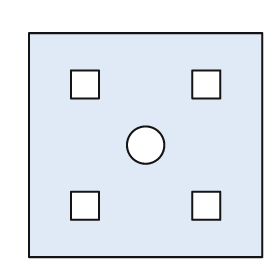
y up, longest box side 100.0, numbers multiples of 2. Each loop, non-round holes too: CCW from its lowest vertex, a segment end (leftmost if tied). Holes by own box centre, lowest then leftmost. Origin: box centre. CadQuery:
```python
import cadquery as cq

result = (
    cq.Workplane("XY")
    .moveTo(-50.0, -48.0)
    .lineTo(50.0, -48.0)
    .lineTo(50.0, 48.0)
    .lineTo(-50.0, 48.0)
    .close()
    .moveTo(-32.0, -32.0)
    .lineTo(-20.0, -32.0)
    .lineTo(-20.0, -20.0)
    .lineTo(-32.0, -20.0)
    .close()
    .moveTo(20.0, -32.0)
    .lineTo(32.0, -32.0)
    .lineTo(32.0, -20.0)
    .lineTo(20.0, -20.0)
    .close()
    .moveTo(0.0, 0.0)
    .circle(8.0)
    .moveTo(-32.0, 20.0)
    .lineTo(-20.0, 20.0)
    .lineTo(-20.0, 32.0)
    .lineTo(-32.0, 32.0)
    .close()
    .moveTo(20.0, 20.0)
    .lineTo(32.0, 20.0)
    .lineTo(32.0, 32.0)
    .lineTo(20.0, 32.0)
    .close()
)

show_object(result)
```